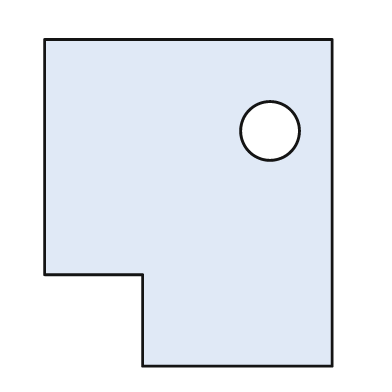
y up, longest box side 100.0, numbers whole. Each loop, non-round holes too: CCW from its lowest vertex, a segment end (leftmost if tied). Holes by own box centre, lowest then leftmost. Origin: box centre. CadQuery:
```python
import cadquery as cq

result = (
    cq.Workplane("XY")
    .moveTo(-14.0, -50.0)
    .lineTo(44.0, -50.0)
    .lineTo(44.0, 50.0)
    .lineTo(-44.0, 50.0)
    .lineTo(-44.0, -22.0)
    .lineTo(-14.0, -22.0)
    .close()
    .moveTo(25.0, 22.0)
    .circle(9.0)
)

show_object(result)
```